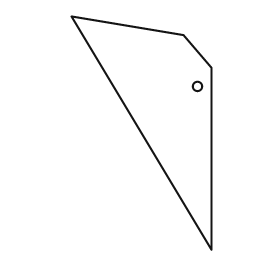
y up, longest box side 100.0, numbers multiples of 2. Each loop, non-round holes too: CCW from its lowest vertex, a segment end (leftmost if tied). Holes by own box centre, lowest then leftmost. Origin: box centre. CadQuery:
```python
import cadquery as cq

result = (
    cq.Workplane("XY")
    .moveTo(30.0, -50.0)
    .lineTo(30.0, 28.0)
    .lineTo(18.0, 42.0)
    .lineTo(-30.0, 50.0)
    .close()
    .moveTo(24.0, 20.0)
    .circle(2.0)
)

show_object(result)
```